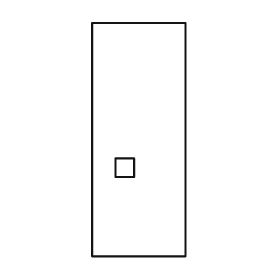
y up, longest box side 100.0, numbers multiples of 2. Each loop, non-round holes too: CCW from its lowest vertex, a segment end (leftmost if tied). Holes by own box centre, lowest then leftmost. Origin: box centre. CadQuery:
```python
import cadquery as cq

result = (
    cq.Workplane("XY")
    .moveTo(-20.0, -50.0)
    .lineTo(20.0, -50.0)
    .lineTo(20.0, 50.0)
    .lineTo(-20.0, 50.0)
    .close()
    .moveTo(-10.0, -16.0)
    .lineTo(-2.0, -16.0)
    .lineTo(-2.0, -8.0)
    .lineTo(-10.0, -8.0)
    .close()
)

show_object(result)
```